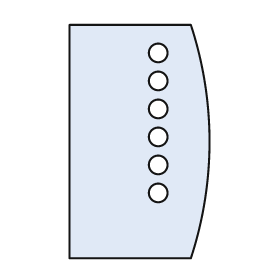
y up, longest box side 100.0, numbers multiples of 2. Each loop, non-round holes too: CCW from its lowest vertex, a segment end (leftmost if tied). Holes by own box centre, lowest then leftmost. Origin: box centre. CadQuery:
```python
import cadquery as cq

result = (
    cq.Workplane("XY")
    .moveTo(-30.0, -50.0)
    .lineTo(22.0, -50.0)
    .threePointArc((30.0, 0.0), (22.0, 50.0))
    .lineTo(-30.0, 50.0)
    .close()
    .moveTo(8.0, -22.0)
    .circle(4.0)
    .moveTo(8.0, -10.0)
    .circle(4.0)
    .moveTo(8.0, 2.0)
    .circle(4.0)
    .moveTo(8.0, 14.0)
    .circle(4.0)
    .moveTo(8.0, 26.0)
    .circle(4.0)
    .moveTo(8.0, 38.0)
    .circle(4.0)
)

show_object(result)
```